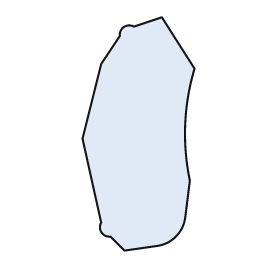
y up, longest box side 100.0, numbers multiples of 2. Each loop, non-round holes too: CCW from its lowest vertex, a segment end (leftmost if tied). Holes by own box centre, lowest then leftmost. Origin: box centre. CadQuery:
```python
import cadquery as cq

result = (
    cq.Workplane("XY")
    .moveTo(-6.0, -50.0)
    .lineTo(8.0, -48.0)
    .threePointArc((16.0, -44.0), (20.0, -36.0))
    .lineTo(22.0, -20.0)
    .threePointArc((20.0, 4.0), (24.0, 28.0))
    .lineTo(10.0, 50.0)
    .lineTo(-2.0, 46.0)
    .threePointArc((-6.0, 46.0), (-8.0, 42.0))
    .lineTo(-16.0, 30.0)
    .lineTo(-24.0, -2.0)
    .lineTo(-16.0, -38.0)
    .threePointArc((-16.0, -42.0), (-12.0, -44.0))
    .close()
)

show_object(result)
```